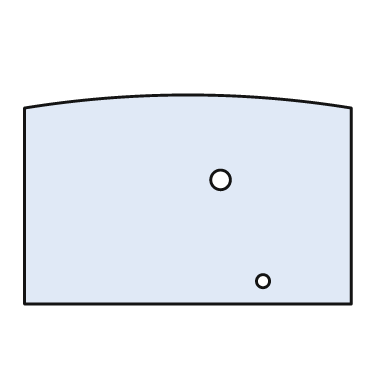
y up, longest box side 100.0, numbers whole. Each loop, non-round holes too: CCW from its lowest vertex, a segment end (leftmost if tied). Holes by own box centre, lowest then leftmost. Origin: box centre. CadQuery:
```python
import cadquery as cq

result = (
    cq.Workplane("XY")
    .moveTo(-50.0, -32.0)
    .lineTo(50.0, -32.0)
    .lineTo(50.0, 28.0)
    .threePointArc((0.0, 32.0), (-50.0, 28.0))
    .close()
    .moveTo(23.0, -25.0)
    .circle(2.0)
    .moveTo(10.0, 6.0)
    .circle(3.0)
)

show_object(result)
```